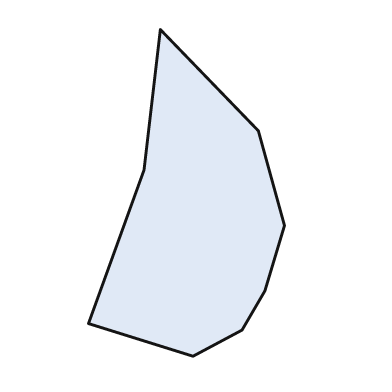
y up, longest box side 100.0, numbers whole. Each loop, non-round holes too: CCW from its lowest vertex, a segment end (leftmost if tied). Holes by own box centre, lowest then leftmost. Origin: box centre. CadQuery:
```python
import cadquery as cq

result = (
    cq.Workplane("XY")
    .moveTo(2.0, -50.0)
    .lineTo(17.0, -42.0)
    .lineTo(24.0, -30.0)
    .lineTo(30.0, -10.0)
    .lineTo(22.0, 19.0)
    .lineTo(-8.0, 50.0)
    .lineTo(-13.0, 7.0)
    .lineTo(-30.0, -40.0)
    .close()
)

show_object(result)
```